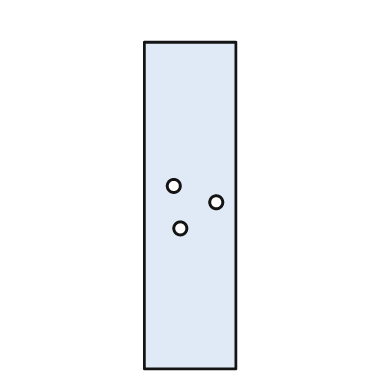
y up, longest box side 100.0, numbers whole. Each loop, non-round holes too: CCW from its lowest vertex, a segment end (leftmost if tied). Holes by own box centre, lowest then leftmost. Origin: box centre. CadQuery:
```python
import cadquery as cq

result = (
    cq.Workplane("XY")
    .moveTo(-14.0, -50.0)
    .lineTo(14.0, -50.0)
    .lineTo(14.0, 50.0)
    .lineTo(-14.0, 50.0)
    .close()
    .moveTo(-3.0, -7.0)
    .circle(2.0)
    .moveTo(8.0, 1.0)
    .circle(2.0)
    .moveTo(-5.0, 6.0)
    .circle(2.0)
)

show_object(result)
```